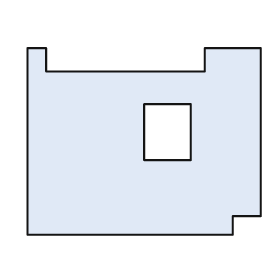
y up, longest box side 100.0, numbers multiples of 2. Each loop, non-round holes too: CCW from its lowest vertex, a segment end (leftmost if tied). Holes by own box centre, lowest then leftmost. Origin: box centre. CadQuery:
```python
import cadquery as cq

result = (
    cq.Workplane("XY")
    .moveTo(-50.0, -40.0)
    .lineTo(38.0, -40.0)
    .lineTo(38.0, -32.0)
    .lineTo(50.0, -32.0)
    .lineTo(50.0, 40.0)
    .lineTo(26.0, 40.0)
    .lineTo(26.0, 30.0)
    .lineTo(-42.0, 30.0)
    .lineTo(-42.0, 40.0)
    .lineTo(-50.0, 40.0)
    .close()
    .moveTo(0.0, -8.0)
    .lineTo(20.0, -8.0)
    .lineTo(20.0, 16.0)
    .lineTo(0.0, 16.0)
    .close()
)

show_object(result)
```